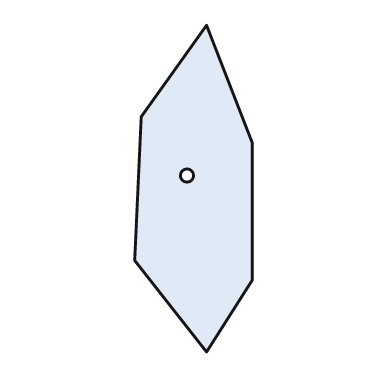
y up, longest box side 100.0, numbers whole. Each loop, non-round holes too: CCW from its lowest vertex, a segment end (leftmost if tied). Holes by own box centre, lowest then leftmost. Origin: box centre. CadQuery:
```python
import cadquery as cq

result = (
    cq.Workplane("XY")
    .moveTo(4.0, -50.0)
    .lineTo(18.0, -28.0)
    .lineTo(18.0, 14.0)
    .lineTo(4.0, 50.0)
    .lineTo(-16.0, 22.0)
    .lineTo(-18.0, -22.0)
    .close()
    .moveTo(-2.0, 4.0)
    .circle(2.0)
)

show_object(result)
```